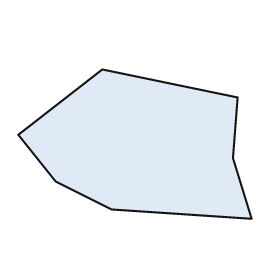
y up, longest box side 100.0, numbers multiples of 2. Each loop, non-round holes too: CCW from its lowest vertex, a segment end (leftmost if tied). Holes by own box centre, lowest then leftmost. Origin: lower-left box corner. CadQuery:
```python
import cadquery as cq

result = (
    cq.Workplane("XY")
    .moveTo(100.0, 0.0)
    .lineTo(92.0, 26.0)
    .lineTo(94.0, 52.0)
    .lineTo(36.0, 64.0)
    .lineTo(0.0, 36.0)
    .lineTo(16.0, 16.0)
    .lineTo(40.0, 4.0)
    .close()
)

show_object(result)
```